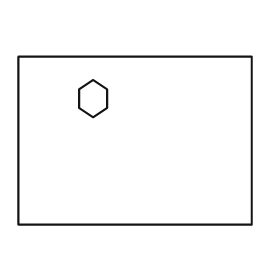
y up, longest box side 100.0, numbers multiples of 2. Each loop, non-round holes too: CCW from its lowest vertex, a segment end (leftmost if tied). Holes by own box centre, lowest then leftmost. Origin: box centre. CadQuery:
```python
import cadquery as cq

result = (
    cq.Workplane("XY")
    .moveTo(-50.0, -36.0)
    .lineTo(50.0, -36.0)
    .lineTo(50.0, 36.0)
    .lineTo(-50.0, 36.0)
    .close()
    .moveTo(-18.0, 10.0)
    .lineTo(-12.0, 14.0)
    .lineTo(-12.0, 22.0)
    .lineTo(-18.0, 26.0)
    .lineTo(-24.0, 22.0)
    .lineTo(-24.0, 14.0)
    .close()
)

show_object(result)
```